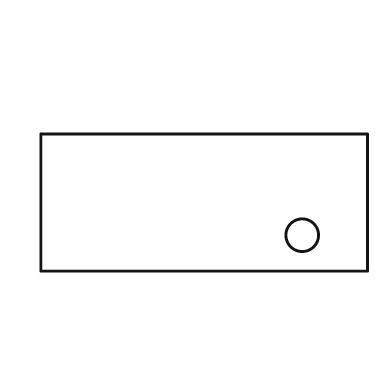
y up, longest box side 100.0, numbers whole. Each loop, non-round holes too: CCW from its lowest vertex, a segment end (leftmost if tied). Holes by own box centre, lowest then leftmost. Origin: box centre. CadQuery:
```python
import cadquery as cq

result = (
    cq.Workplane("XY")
    .moveTo(-50.0, -21.0)
    .lineTo(50.0, -21.0)
    .lineTo(50.0, 21.0)
    .lineTo(-50.0, 21.0)
    .close()
    .moveTo(30.0, -10.0)
    .circle(5.0)
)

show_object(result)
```